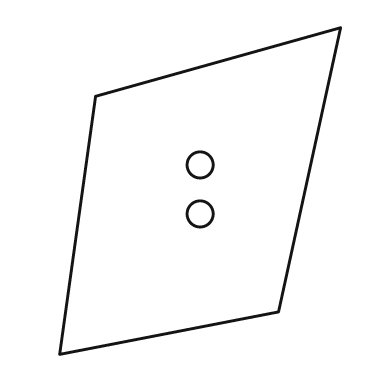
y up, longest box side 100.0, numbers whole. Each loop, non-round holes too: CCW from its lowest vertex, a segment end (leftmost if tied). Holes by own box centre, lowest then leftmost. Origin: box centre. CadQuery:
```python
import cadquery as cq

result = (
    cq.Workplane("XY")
    .moveTo(-43.0, -50.0)
    .lineTo(24.0, -37.0)
    .lineTo(43.0, 50.0)
    .lineTo(-32.0, 29.0)
    .close()
    .moveTo(0.0, -7.0)
    .circle(4.0)
    .moveTo(0.0, 8.0)
    .circle(4.0)
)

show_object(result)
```